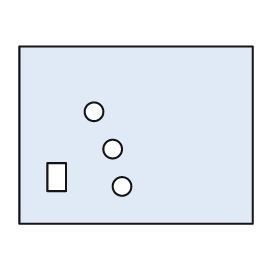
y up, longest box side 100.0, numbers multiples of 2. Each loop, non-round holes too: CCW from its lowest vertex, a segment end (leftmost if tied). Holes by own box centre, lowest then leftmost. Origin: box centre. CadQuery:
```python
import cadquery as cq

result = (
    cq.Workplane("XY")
    .moveTo(-50.0, -38.0)
    .lineTo(50.0, -38.0)
    .lineTo(50.0, 38.0)
    .lineTo(-50.0, 38.0)
    .close()
    .moveTo(-6.0, -22.0)
    .circle(4.0)
    .moveTo(-38.0, -24.0)
    .lineTo(-30.0, -24.0)
    .lineTo(-30.0, -12.0)
    .lineTo(-38.0, -12.0)
    .close()
    .moveTo(-10.0, -6.0)
    .circle(4.0)
    .moveTo(-18.0, 10.0)
    .circle(4.0)
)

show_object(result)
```